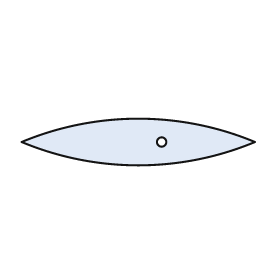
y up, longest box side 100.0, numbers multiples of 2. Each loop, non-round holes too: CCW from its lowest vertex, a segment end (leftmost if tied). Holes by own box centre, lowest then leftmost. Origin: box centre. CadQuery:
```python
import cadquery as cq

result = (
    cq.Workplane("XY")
    .moveTo(-50.0, 0.0)
    .threePointArc((0.0, -10.0), (50.0, 0.0))
    .threePointArc((0.0, 10.0), (-50.0, 0.0))
    .close()
    .moveTo(10.0, 0.0)
    .circle(2.0)
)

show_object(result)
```